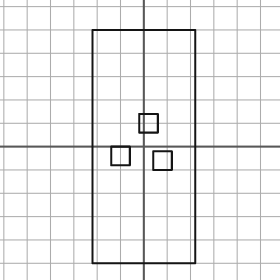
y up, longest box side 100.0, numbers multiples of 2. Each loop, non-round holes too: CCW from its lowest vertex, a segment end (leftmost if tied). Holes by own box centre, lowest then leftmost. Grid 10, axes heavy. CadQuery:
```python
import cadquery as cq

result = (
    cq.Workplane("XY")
    .moveTo(-22.0, -50.0)
    .lineTo(22.0, -50.0)
    .lineTo(22.0, 50.0)
    .lineTo(-22.0, 50.0)
    .close()
    .moveTo(4.0, -10.0)
    .lineTo(12.0, -10.0)
    .lineTo(12.0, -2.0)
    .lineTo(4.0, -2.0)
    .close()
    .moveTo(-14.0, -8.0)
    .lineTo(-6.0, -8.0)
    .lineTo(-6.0, 0.0)
    .lineTo(-14.0, 0.0)
    .close()
    .moveTo(-2.0, 6.0)
    .lineTo(6.0, 6.0)
    .lineTo(6.0, 14.0)
    .lineTo(-2.0, 14.0)
    .close()
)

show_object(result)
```